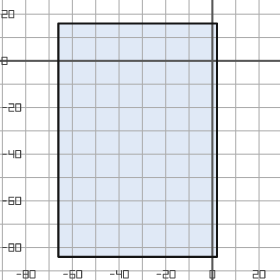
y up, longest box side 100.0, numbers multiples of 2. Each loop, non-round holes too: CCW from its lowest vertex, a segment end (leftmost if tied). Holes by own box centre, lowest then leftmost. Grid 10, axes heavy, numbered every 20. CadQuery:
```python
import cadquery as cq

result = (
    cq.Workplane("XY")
    .moveTo(-66.0, -84.0)
    .lineTo(2.0, -84.0)
    .lineTo(2.0, 16.0)
    .lineTo(-66.0, 16.0)
    .close()
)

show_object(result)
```